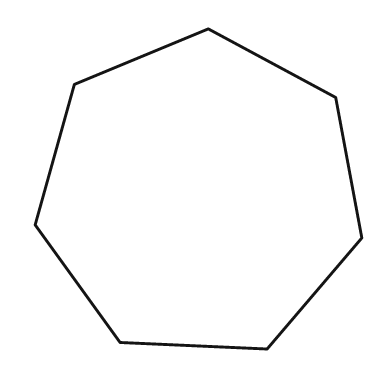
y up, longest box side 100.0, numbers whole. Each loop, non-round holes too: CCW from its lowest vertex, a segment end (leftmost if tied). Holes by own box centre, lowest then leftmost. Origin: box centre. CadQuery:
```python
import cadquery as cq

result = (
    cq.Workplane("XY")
    .moveTo(21.0, -49.0)
    .lineTo(50.0, -15.0)
    .lineTo(42.0, 28.0)
    .lineTo(3.0, 49.0)
    .lineTo(-38.0, 32.0)
    .lineTo(-50.0, -11.0)
    .lineTo(-24.0, -47.0)
    .close()
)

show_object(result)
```